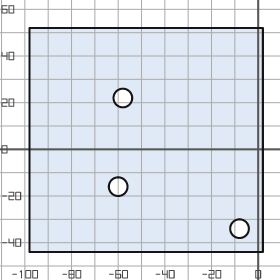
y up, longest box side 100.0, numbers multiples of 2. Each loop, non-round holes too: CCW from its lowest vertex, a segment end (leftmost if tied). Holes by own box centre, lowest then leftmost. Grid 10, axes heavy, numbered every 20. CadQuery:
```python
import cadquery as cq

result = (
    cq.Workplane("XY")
    .moveTo(-98.0, -44.0)
    .lineTo(2.0, -44.0)
    .lineTo(2.0, 52.0)
    .lineTo(-98.0, 52.0)
    .close()
    .moveTo(-8.0, -34.0)
    .circle(4.0)
    .moveTo(-60.0, -16.0)
    .circle(4.0)
    .moveTo(-58.0, 22.0)
    .circle(4.0)
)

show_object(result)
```